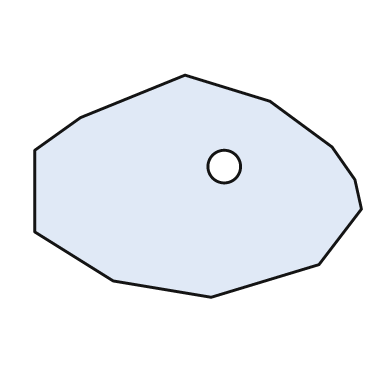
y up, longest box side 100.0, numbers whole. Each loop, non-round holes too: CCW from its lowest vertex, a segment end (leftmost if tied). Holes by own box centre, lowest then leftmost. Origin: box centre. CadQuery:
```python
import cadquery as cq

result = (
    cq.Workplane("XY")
    .moveTo(4.0, -34.0)
    .lineTo(37.0, -24.0)
    .lineTo(50.0, -7.0)
    .lineTo(48.0, 2.0)
    .lineTo(41.0, 12.0)
    .lineTo(22.0, 26.0)
    .lineTo(-4.0, 34.0)
    .lineTo(-36.0, 21.0)
    .lineTo(-50.0, 11.0)
    .lineTo(-50.0, -14.0)
    .lineTo(-26.0, -29.0)
    .close()
    .moveTo(8.0, 6.0)
    .circle(5.0)
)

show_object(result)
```